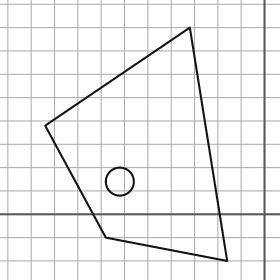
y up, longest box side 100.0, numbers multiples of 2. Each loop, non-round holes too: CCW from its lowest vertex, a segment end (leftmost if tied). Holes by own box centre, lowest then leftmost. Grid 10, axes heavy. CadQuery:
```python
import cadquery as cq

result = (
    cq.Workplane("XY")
    .moveTo(-16.0, -20.0)
    .lineTo(-32.0, 80.0)
    .lineTo(-94.0, 38.0)
    .lineTo(-68.0, -10.0)
    .close()
    .moveTo(-62.0, 14.0)
    .circle(6.0)
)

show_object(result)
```